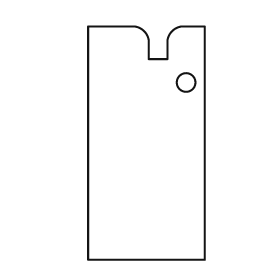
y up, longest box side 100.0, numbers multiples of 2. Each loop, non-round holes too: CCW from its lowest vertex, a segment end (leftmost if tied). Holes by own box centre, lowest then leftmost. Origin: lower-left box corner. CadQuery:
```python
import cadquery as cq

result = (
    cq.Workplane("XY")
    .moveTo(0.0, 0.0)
    .lineTo(50.0, 0.0)
    .lineTo(50.0, 100.0)
    .lineTo(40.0, 100.0)
    .threePointArc((36.0, 98.0), (34.0, 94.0))
    .lineTo(34.0, 86.0)
    .lineTo(26.0, 86.0)
    .lineTo(26.0, 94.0)
    .threePointArc((24.0, 98.0), (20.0, 100.0))
    .lineTo(0.0, 100.0)
    .close()
    .moveTo(42.0, 76.0)
    .circle(4.0)
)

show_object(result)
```